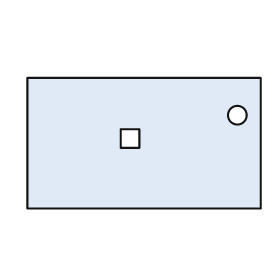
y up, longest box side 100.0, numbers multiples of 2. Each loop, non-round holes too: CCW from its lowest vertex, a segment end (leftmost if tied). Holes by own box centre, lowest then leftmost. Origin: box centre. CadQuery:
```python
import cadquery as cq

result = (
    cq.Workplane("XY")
    .moveTo(-50.0, -28.0)
    .lineTo(50.0, -28.0)
    .lineTo(50.0, 28.0)
    .lineTo(-50.0, 28.0)
    .close()
    .moveTo(-10.0, -2.0)
    .lineTo(-2.0, -2.0)
    .lineTo(-2.0, 6.0)
    .lineTo(-10.0, 6.0)
    .close()
    .moveTo(40.0, 12.0)
    .circle(4.0)
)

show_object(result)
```